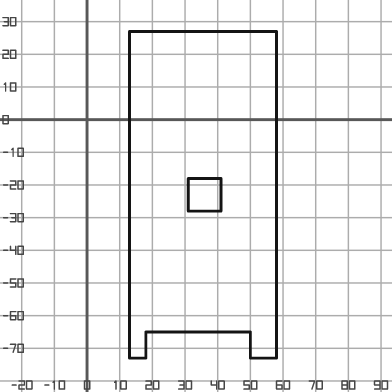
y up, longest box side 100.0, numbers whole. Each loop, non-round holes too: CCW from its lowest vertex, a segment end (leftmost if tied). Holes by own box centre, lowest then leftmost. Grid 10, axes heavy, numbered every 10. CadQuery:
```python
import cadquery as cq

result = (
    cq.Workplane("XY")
    .moveTo(13.0, -73.0)
    .lineTo(18.0, -73.0)
    .lineTo(18.0, -65.0)
    .lineTo(50.0, -65.0)
    .lineTo(50.0, -73.0)
    .lineTo(58.0, -73.0)
    .lineTo(58.0, 27.0)
    .lineTo(13.0, 27.0)
    .close()
    .moveTo(31.0, -28.0)
    .lineTo(41.0, -28.0)
    .lineTo(41.0, -18.0)
    .lineTo(31.0, -18.0)
    .close()
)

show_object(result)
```